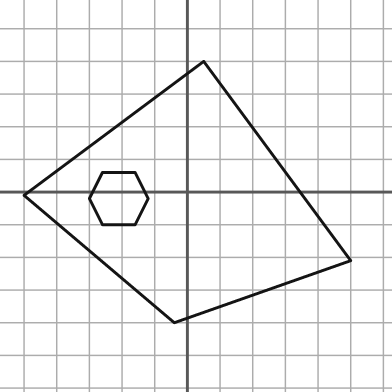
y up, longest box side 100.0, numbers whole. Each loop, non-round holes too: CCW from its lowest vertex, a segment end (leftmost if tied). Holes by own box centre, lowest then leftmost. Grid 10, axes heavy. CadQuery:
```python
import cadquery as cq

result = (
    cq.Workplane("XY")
    .moveTo(-4.0, -40.0)
    .lineTo(50.0, -21.0)
    .lineTo(5.0, 40.0)
    .lineTo(-50.0, -1.0)
    .close()
    .moveTo(-26.0, -10.0)
    .lineTo(-16.0, -10.0)
    .lineTo(-12.0, -2.0)
    .lineTo(-16.0, 6.0)
    .lineTo(-26.0, 6.0)
    .lineTo(-30.0, -2.0)
    .close()
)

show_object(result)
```